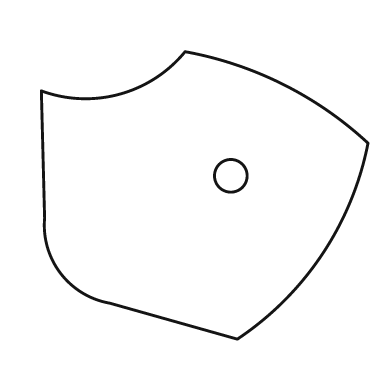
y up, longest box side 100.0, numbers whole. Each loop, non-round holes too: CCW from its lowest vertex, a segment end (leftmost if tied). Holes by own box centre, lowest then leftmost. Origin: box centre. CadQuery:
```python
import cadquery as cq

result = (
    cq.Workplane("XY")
    .moveTo(10.0, -44.0)
    .threePointArc((36.0, -18.0), (50.0, 16.0))
    .threePointArc((24.0, 34.0), (-6.0, 44.0))
    .threePointArc((-26.0, 31.0), (-50.0, 32.0))
    .lineTo(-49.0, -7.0)
    .threePointArc((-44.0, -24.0), (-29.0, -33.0))
    .close()
    .moveTo(8.0, 6.0)
    .circle(5.0)
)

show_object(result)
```